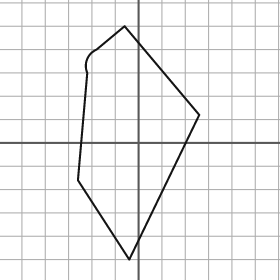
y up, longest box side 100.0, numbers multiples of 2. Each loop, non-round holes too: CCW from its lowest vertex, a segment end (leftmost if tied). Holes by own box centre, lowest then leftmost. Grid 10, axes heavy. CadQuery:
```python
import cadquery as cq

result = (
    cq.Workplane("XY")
    .moveTo(-4.0, -50.0)
    .lineTo(26.0, 12.0)
    .lineTo(-6.0, 50.0)
    .lineTo(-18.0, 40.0)
    .threePointArc((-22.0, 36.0), (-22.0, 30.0))
    .lineTo(-26.0, -16.0)
    .close()
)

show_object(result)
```